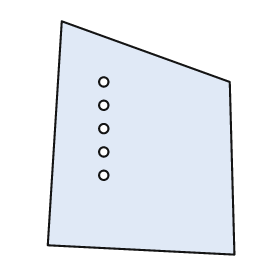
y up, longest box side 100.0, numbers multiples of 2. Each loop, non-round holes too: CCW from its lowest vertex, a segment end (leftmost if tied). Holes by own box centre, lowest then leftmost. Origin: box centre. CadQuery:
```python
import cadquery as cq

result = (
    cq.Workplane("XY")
    .moveTo(40.0, -50.0)
    .lineTo(38.0, 24.0)
    .lineTo(-34.0, 50.0)
    .lineTo(-40.0, -46.0)
    .close()
    .moveTo(-16.0, -16.0)
    .circle(2.0)
    .moveTo(-16.0, -6.0)
    .circle(2.0)
    .moveTo(-16.0, 4.0)
    .circle(2.0)
    .moveTo(-16.0, 14.0)
    .circle(2.0)
    .moveTo(-16.0, 24.0)
    .circle(2.0)
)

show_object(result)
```